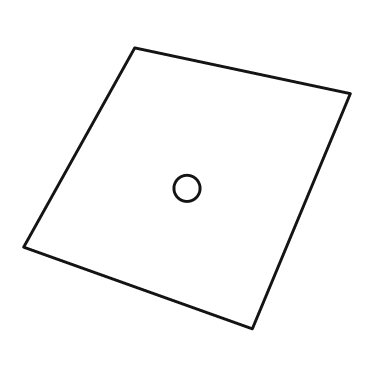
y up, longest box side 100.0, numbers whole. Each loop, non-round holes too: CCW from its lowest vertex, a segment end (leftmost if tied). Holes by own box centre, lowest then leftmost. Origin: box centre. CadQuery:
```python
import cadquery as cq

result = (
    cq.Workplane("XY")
    .moveTo(20.0, -43.0)
    .lineTo(50.0, 29.0)
    .lineTo(-16.0, 43.0)
    .lineTo(-50.0, -18.0)
    .close()
    .moveTo(0.0, 0.0)
    .circle(4.0)
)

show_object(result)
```